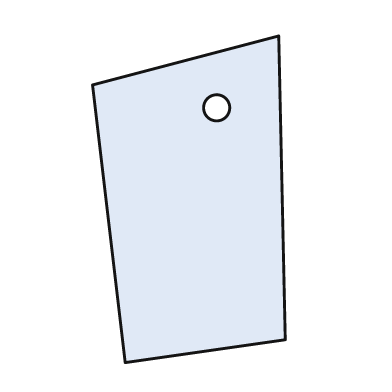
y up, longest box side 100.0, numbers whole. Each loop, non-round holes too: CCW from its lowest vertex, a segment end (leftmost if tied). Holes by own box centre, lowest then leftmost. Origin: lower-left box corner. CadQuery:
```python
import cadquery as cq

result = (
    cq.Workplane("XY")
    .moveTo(10.0, 0.0)
    .lineTo(59.0, 7.0)
    .lineTo(57.0, 100.0)
    .lineTo(0.0, 85.0)
    .close()
    .moveTo(38.0, 78.0)
    .circle(4.0)
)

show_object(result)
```